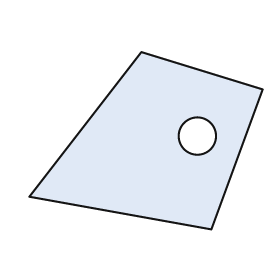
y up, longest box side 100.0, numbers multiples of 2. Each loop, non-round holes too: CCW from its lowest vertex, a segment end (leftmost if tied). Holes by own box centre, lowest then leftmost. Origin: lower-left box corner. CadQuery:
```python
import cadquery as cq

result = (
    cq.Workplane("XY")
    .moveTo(78.0, 0.0)
    .lineTo(100.0, 60.0)
    .lineTo(48.0, 76.0)
    .lineTo(0.0, 14.0)
    .close()
    .moveTo(72.0, 40.0)
    .circle(8.0)
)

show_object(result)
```